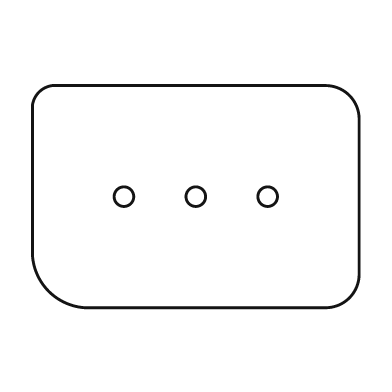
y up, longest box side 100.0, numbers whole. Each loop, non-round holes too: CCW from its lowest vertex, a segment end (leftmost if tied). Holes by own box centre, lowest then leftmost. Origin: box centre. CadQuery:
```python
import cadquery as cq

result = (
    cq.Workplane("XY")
    .moveTo(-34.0, -34.0)
    .lineTo(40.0, -34.0)
    .threePointArc((47.0, -31.0), (50.0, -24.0))
    .lineTo(50.0, 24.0)
    .threePointArc((47.0, 31.0), (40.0, 34.0))
    .lineTo(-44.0, 34.0)
    .threePointArc((-48.0, 32.0), (-50.0, 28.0))
    .lineTo(-50.0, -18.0)
    .threePointArc((-45.0, -29.0), (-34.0, -34.0))
    .close()
    .moveTo(-22.0, 0.0)
    .circle(3.0)
    .moveTo(0.0, 0.0)
    .circle(3.0)
    .moveTo(22.0, 0.0)
    .circle(3.0)
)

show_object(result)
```